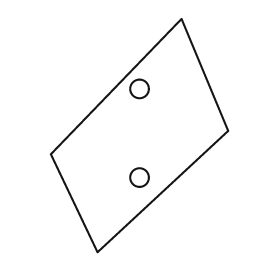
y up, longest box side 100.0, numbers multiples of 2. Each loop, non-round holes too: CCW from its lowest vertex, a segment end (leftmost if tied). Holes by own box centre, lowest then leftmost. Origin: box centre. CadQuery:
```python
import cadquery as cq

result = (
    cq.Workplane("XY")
    .moveTo(-18.0, -50.0)
    .lineTo(38.0, 2.0)
    .lineTo(18.0, 50.0)
    .lineTo(-38.0, -8.0)
    .close()
    .moveTo(0.0, -18.0)
    .circle(4.0)
    .moveTo(0.0, 20.0)
    .circle(4.0)
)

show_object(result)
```